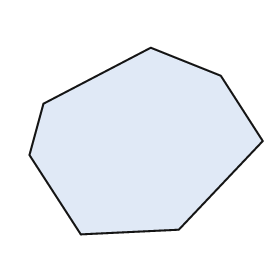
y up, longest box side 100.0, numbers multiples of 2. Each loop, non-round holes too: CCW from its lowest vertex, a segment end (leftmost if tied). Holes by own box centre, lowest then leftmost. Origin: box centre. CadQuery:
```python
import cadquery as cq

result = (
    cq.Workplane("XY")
    .moveTo(-28.0, -40.0)
    .lineTo(14.0, -38.0)
    .lineTo(50.0, 0.0)
    .lineTo(32.0, 28.0)
    .lineTo(2.0, 40.0)
    .lineTo(-44.0, 16.0)
    .lineTo(-50.0, -6.0)
    .close()
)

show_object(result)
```